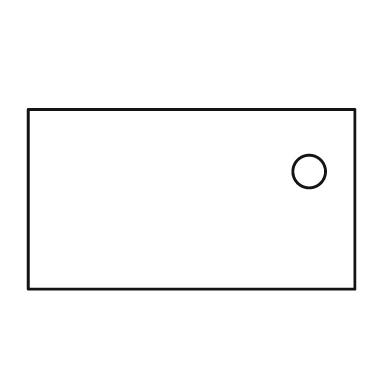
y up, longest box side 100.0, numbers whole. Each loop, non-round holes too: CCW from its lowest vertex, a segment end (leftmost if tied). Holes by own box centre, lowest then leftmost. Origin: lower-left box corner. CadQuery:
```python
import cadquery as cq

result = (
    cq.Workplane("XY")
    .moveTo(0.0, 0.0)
    .lineTo(100.0, 0.0)
    .lineTo(100.0, 55.0)
    .lineTo(0.0, 55.0)
    .close()
    .moveTo(86.0, 36.0)
    .circle(5.0)
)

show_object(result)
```